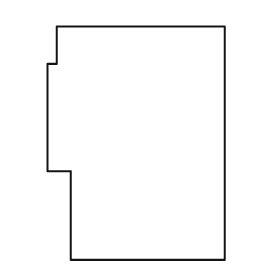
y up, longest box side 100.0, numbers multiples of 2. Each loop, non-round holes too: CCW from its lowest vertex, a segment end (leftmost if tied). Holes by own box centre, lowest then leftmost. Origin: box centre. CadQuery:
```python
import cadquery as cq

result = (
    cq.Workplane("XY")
    .moveTo(-28.0, -50.0)
    .lineTo(38.0, -50.0)
    .lineTo(38.0, 50.0)
    .lineTo(-34.0, 50.0)
    .lineTo(-34.0, 34.0)
    .lineTo(-38.0, 34.0)
    .lineTo(-38.0, -12.0)
    .lineTo(-28.0, -12.0)
    .close()
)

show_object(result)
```